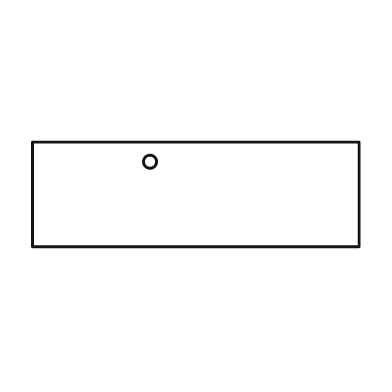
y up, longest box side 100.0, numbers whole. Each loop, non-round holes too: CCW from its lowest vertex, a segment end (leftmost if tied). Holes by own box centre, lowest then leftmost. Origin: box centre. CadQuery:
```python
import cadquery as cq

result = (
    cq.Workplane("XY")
    .moveTo(-50.0, -16.0)
    .lineTo(50.0, -16.0)
    .lineTo(50.0, 16.0)
    .lineTo(-50.0, 16.0)
    .close()
    .moveTo(-14.0, 10.0)
    .circle(2.0)
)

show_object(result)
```